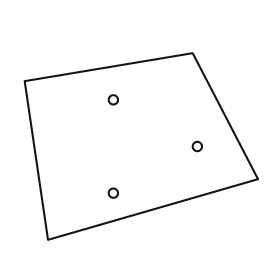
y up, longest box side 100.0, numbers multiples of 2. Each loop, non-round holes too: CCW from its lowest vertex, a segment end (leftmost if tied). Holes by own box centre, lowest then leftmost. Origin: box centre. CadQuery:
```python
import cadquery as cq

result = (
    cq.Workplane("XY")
    .moveTo(-40.0, -40.0)
    .lineTo(50.0, -14.0)
    .lineTo(22.0, 40.0)
    .lineTo(-50.0, 28.0)
    .close()
    .moveTo(-12.0, -20.0)
    .circle(2.0)
    .moveTo(24.0, 0.0)
    .circle(2.0)
    .moveTo(-12.0, 20.0)
    .circle(2.0)
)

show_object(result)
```